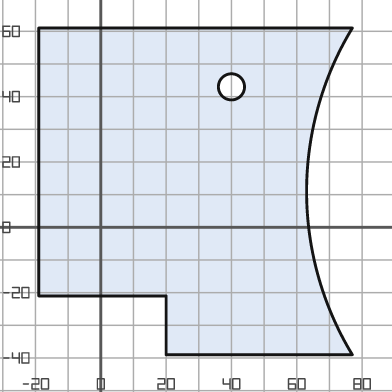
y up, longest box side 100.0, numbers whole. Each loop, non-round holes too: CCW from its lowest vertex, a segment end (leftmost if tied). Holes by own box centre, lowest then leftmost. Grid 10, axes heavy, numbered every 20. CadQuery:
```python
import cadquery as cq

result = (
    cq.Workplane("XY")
    .moveTo(20.0, -39.0)
    .lineTo(77.0, -39.0)
    .threePointArc((63.0, 11.0), (77.0, 61.0))
    .lineTo(-19.0, 61.0)
    .lineTo(-19.0, -21.0)
    .lineTo(20.0, -21.0)
    .close()
    .moveTo(40.0, 43.0)
    .circle(4.0)
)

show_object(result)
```